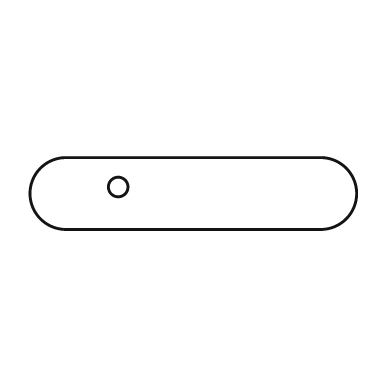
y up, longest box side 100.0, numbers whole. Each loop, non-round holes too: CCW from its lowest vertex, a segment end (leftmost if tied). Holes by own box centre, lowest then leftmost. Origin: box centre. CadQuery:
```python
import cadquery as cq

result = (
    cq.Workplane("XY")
    .moveTo(-39.0, -11.0)
    .lineTo(39.0, -11.0)
    .threePointArc((50.0, 0.0), (39.0, 11.0))
    .lineTo(-39.0, 11.0)
    .threePointArc((-50.0, 0.0), (-39.0, -11.0))
    .close()
    .moveTo(-23.0, 2.0)
    .circle(3.0)
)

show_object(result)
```